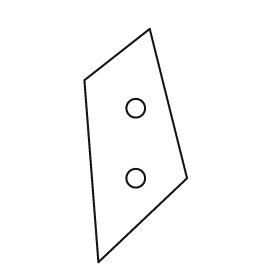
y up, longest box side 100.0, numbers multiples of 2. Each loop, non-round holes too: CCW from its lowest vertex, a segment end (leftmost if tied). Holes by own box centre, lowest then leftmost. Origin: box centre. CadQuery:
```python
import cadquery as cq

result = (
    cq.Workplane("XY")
    .moveTo(-16.0, -50.0)
    .lineTo(22.0, -14.0)
    .lineTo(6.0, 50.0)
    .lineTo(-22.0, 28.0)
    .close()
    .moveTo(0.0, -14.0)
    .circle(4.0)
    .moveTo(0.0, 16.0)
    .circle(4.0)
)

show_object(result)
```